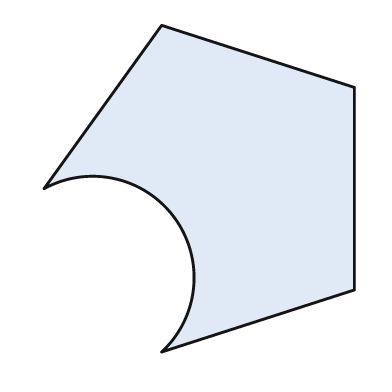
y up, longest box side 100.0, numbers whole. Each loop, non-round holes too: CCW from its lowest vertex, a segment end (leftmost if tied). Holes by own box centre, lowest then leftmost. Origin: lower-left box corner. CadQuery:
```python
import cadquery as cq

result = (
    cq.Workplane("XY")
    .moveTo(36.0, 0.0)
    .lineTo(95.0, 19.0)
    .lineTo(95.0, 81.0)
    .lineTo(36.0, 100.0)
    .lineTo(0.0, 50.0)
    .threePointArc((40.0, 41.0), (36.0, 0.0))
    .close()
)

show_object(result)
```